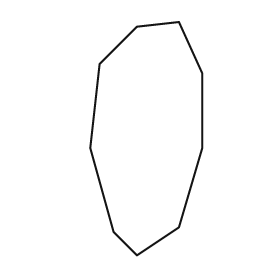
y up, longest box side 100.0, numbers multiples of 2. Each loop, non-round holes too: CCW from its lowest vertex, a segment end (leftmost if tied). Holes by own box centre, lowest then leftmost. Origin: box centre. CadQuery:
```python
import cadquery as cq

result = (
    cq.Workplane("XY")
    .moveTo(-4.0, -50.0)
    .lineTo(14.0, -38.0)
    .lineTo(24.0, -4.0)
    .lineTo(24.0, 28.0)
    .lineTo(14.0, 50.0)
    .lineTo(-4.0, 48.0)
    .lineTo(-20.0, 32.0)
    .lineTo(-24.0, -4.0)
    .lineTo(-14.0, -40.0)
    .close()
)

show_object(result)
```